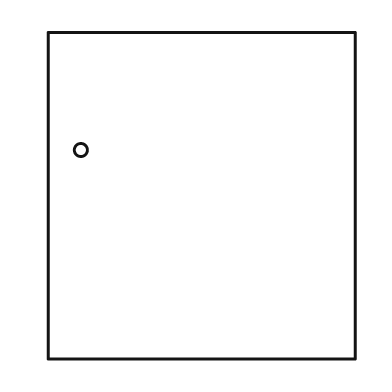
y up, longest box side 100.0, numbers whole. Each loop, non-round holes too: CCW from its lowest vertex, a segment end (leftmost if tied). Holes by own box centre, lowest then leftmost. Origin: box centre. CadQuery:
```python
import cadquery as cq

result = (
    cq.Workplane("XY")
    .moveTo(-47.0, -50.0)
    .lineTo(47.0, -50.0)
    .lineTo(47.0, 50.0)
    .lineTo(-47.0, 50.0)
    .close()
    .moveTo(-37.0, 14.0)
    .circle(2.0)
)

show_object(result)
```